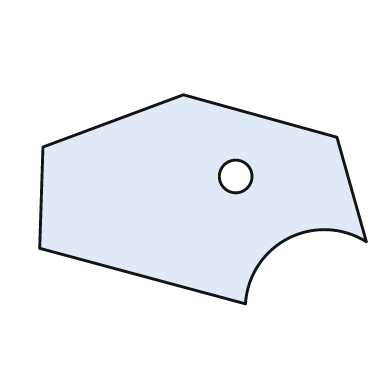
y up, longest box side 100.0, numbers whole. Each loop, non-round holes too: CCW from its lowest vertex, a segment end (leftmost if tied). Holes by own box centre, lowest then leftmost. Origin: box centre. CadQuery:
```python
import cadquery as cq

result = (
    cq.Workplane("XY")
    .moveTo(13.0, -32.0)
    .threePointArc((26.0, -12.0), (50.0, -13.0))
    .lineTo(41.0, 19.0)
    .lineTo(-6.0, 32.0)
    .lineTo(-49.0, 16.0)
    .lineTo(-50.0, -15.0)
    .close()
    .moveTo(10.0, 7.0)
    .circle(5.0)
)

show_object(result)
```